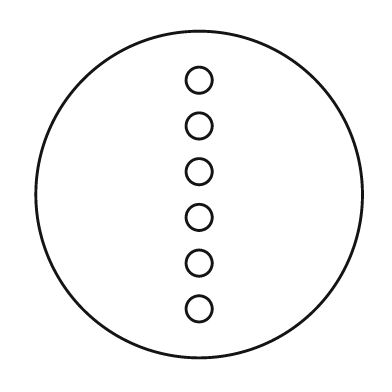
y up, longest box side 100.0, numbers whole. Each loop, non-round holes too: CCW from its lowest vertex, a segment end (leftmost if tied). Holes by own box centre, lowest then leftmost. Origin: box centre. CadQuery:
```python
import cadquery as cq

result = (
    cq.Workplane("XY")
    .moveTo(0.0, 0.0)
    .circle(50.0)
    .moveTo(0.0, -35.0)
    .circle(4.0)
    .moveTo(0.0, -21.0)
    .circle(4.0)
    .moveTo(0.0, -7.0)
    .circle(4.0)
    .moveTo(0.0, 7.0)
    .circle(4.0)
    .moveTo(0.0, 21.0)
    .circle(4.0)
    .moveTo(0.0, 35.0)
    .circle(4.0)
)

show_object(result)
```